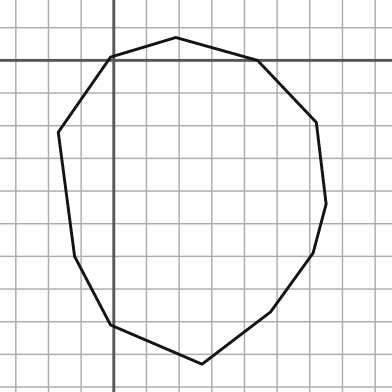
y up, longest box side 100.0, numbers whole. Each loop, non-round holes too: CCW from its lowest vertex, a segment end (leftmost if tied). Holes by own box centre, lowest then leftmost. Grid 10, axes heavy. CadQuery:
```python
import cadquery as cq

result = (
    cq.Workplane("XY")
    .moveTo(27.0, -93.0)
    .lineTo(48.0, -77.0)
    .lineTo(61.0, -59.0)
    .lineTo(65.0, -44.0)
    .lineTo(62.0, -19.0)
    .lineTo(44.0, 0.0)
    .lineTo(19.0, 7.0)
    .lineTo(-1.0, 1.0)
    .lineTo(-17.0, -22.0)
    .lineTo(-12.0, -60.0)
    .lineTo(-1.0, -81.0)
    .close()
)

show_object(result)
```